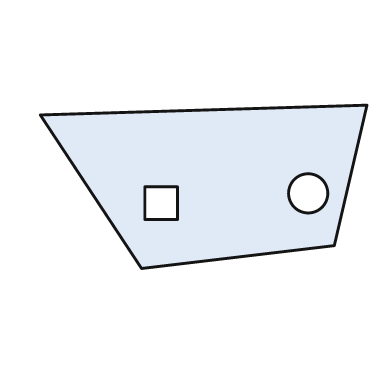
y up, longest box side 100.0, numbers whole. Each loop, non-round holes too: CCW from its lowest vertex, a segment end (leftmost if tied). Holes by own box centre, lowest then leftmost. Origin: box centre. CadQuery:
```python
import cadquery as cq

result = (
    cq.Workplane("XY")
    .moveTo(-19.0, -25.0)
    .lineTo(40.0, -18.0)
    .lineTo(50.0, 25.0)
    .lineTo(-50.0, 22.0)
    .close()
    .moveTo(-18.0, -10.0)
    .lineTo(-8.0, -10.0)
    .lineTo(-8.0, 0.0)
    .lineTo(-18.0, 0.0)
    .close()
    .moveTo(32.0, -2.0)
    .circle(6.0)
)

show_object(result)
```